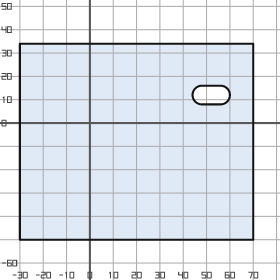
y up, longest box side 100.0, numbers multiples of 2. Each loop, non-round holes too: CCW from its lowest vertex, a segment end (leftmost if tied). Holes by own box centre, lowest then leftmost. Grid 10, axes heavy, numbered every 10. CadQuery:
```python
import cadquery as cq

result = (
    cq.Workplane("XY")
    .moveTo(-30.0, -50.0)
    .lineTo(70.0, -50.0)
    .lineTo(70.0, 34.0)
    .lineTo(-30.0, 34.0)
    .close()
    .moveTo(48.0, 8.0)
    .lineTo(56.0, 8.0)
    .threePointArc((60.0, 12.0), (56.0, 16.0))
    .lineTo(48.0, 16.0)
    .threePointArc((44.0, 12.0), (48.0, 8.0))
    .close()
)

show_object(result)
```